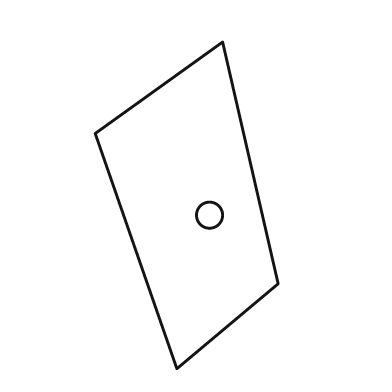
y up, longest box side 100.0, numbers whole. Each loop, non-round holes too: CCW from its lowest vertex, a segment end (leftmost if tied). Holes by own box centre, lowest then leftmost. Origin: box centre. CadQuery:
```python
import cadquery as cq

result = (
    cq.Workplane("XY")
    .moveTo(-3.0, -50.0)
    .lineTo(28.0, -24.0)
    .lineTo(11.0, 50.0)
    .lineTo(-28.0, 22.0)
    .close()
    .moveTo(7.0, -3.0)
    .circle(4.0)
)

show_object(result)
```